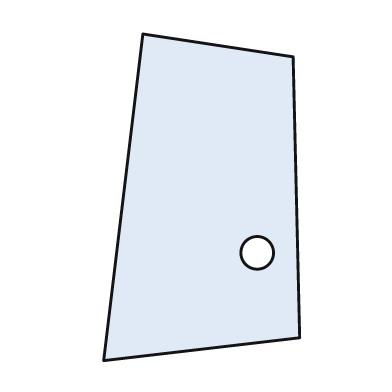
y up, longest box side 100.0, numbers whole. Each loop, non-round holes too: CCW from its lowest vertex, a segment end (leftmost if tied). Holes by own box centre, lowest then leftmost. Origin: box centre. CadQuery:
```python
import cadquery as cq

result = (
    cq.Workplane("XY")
    .moveTo(-30.0, -50.0)
    .lineTo(30.0, -43.0)
    .lineTo(28.0, 43.0)
    .lineTo(-18.0, 50.0)
    .close()
    .moveTo(17.0, -17.0)
    .circle(5.0)
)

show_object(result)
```